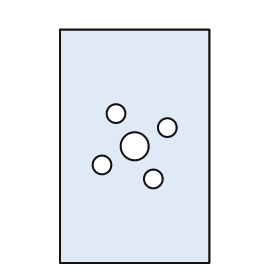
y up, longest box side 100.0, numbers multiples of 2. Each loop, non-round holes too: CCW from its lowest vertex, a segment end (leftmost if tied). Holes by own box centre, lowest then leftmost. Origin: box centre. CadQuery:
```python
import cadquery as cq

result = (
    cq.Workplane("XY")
    .moveTo(-32.0, -50.0)
    .lineTo(32.0, -50.0)
    .lineTo(32.0, 50.0)
    .lineTo(-32.0, 50.0)
    .close()
    .moveTo(8.0, -14.0)
    .circle(4.0)
    .moveTo(-14.0, -8.0)
    .circle(4.0)
    .moveTo(0.0, 0.0)
    .circle(6.0)
    .moveTo(14.0, 8.0)
    .circle(4.0)
    .moveTo(-8.0, 14.0)
    .circle(4.0)
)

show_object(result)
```